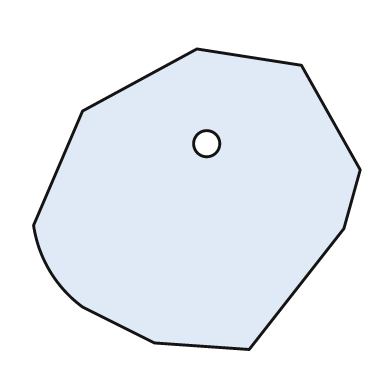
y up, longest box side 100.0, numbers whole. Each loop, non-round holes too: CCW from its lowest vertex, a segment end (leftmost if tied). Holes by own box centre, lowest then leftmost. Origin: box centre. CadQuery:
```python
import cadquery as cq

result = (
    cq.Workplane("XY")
    .moveTo(16.0, -46.0)
    .lineTo(45.0, -9.0)
    .lineTo(50.0, 9.0)
    .lineTo(32.0, 41.0)
    .lineTo(0.0, 46.0)
    .lineTo(-35.0, 27.0)
    .lineTo(-50.0, -8.0)
    .threePointArc((-45.0, -22.0), (-35.0, -33.0))
    .lineTo(-13.0, -44.0)
    .close()
    .moveTo(3.0, 17.0)
    .circle(4.0)
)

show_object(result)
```